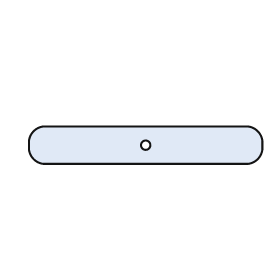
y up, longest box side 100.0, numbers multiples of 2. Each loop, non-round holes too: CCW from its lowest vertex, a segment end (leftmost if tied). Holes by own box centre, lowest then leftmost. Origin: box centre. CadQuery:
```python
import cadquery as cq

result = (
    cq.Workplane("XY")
    .moveTo(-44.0, -8.0)
    .lineTo(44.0, -8.0)
    .threePointArc((48.0, -6.0), (50.0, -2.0))
    .lineTo(50.0, 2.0)
    .threePointArc((48.0, 6.0), (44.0, 8.0))
    .lineTo(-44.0, 8.0)
    .threePointArc((-48.0, 6.0), (-50.0, 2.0))
    .lineTo(-50.0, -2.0)
    .threePointArc((-48.0, -6.0), (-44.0, -8.0))
    .close()
    .moveTo(0.0, 0.0)
    .circle(2.0)
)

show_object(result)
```